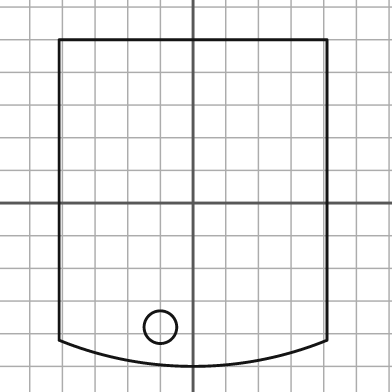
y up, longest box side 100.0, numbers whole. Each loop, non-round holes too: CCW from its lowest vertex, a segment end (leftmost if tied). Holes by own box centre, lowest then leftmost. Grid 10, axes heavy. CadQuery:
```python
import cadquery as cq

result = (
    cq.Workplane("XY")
    .moveTo(-41.0, -42.0)
    .threePointArc((0.0, -50.0), (41.0, -42.0))
    .lineTo(41.0, 50.0)
    .lineTo(-41.0, 50.0)
    .close()
    .moveTo(-10.0, -38.0)
    .circle(5.0)
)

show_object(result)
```